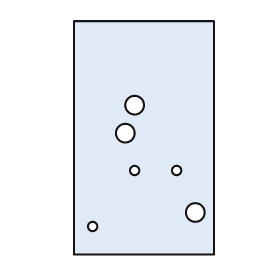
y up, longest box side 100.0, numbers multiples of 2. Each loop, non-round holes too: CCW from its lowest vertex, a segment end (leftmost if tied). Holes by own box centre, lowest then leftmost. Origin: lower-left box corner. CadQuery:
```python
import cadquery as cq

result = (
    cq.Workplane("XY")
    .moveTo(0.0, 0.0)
    .lineTo(60.0, 0.0)
    .lineTo(60.0, 100.0)
    .lineTo(0.0, 100.0)
    .close()
    .moveTo(8.0, 12.0)
    .circle(2.0)
    .moveTo(52.0, 18.0)
    .circle(4.0)
    .moveTo(26.0, 36.0)
    .circle(2.0)
    .moveTo(44.0, 36.0)
    .circle(2.0)
    .moveTo(22.0, 52.0)
    .circle(4.0)
    .moveTo(26.0, 64.0)
    .circle(4.0)
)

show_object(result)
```